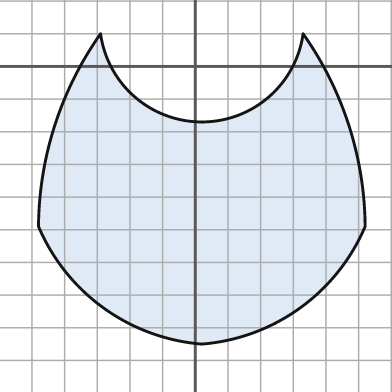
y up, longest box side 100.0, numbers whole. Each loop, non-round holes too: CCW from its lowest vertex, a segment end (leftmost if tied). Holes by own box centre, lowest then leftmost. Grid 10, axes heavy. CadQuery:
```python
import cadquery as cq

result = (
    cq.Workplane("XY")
    .moveTo(2.0, -85.0)
    .threePointArc((32.0, -74.0), (52.0, -49.0))
    .threePointArc((47.0, -18.0), (33.0, 10.0))
    .threePointArc((2.0, -17.0), (-29.0, 10.0))
    .threePointArc((-43.0, -18.0), (-48.0, -49.0))
    .threePointArc((-28.0, -74.0), (2.0, -85.0))
    .close()
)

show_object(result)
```